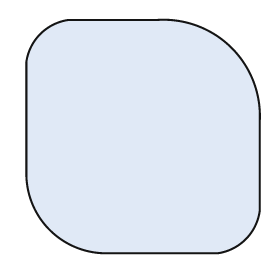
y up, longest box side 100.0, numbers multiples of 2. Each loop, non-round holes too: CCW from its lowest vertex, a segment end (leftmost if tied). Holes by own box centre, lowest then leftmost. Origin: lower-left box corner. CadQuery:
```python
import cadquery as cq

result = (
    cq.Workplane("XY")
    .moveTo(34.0, 0.0)
    .lineTo(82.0, 0.0)
    .threePointArc((94.0, 6.0), (100.0, 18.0))
    .lineTo(100.0, 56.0)
    .threePointArc((88.0, 88.0), (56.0, 100.0))
    .lineTo(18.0, 100.0)
    .threePointArc((6.0, 94.0), (0.0, 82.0))
    .lineTo(0.0, 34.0)
    .threePointArc((10.0, 10.0), (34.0, 0.0))
    .close()
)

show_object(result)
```